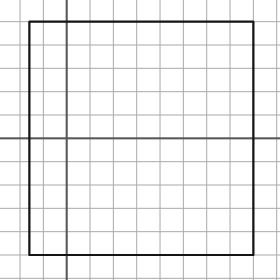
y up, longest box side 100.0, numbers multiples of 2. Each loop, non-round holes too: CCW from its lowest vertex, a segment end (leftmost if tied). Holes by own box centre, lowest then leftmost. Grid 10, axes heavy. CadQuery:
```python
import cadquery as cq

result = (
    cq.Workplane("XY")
    .moveTo(-16.0, -50.0)
    .lineTo(80.0, -50.0)
    .lineTo(80.0, 50.0)
    .lineTo(-16.0, 50.0)
    .close()
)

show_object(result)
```